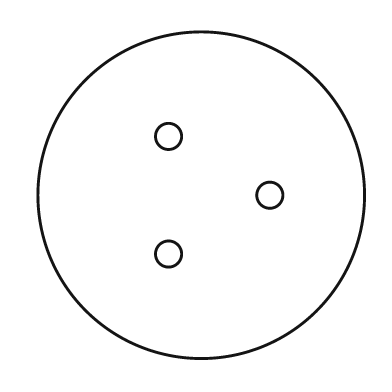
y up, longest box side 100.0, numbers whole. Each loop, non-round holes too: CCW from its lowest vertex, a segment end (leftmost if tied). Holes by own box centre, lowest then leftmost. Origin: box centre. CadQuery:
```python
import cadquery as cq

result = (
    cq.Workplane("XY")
    .moveTo(0.0, 0.0)
    .circle(50.0)
    .moveTo(-10.0, -18.0)
    .circle(4.0)
    .moveTo(21.0, 0.0)
    .circle(4.0)
    .moveTo(-10.0, 18.0)
    .circle(4.0)
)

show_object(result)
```